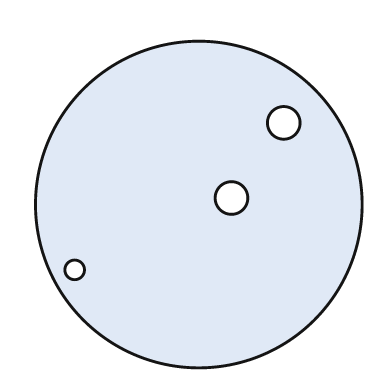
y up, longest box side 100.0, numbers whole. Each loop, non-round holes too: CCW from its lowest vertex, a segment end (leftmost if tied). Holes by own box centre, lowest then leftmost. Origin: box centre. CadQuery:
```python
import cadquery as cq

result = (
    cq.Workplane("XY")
    .moveTo(0.0, 0.0)
    .circle(50.0)
    .moveTo(-38.0, -20.0)
    .circle(3.0)
    .moveTo(10.0, 2.0)
    .circle(5.0)
    .moveTo(26.0, 25.0)
    .circle(5.0)
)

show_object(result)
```